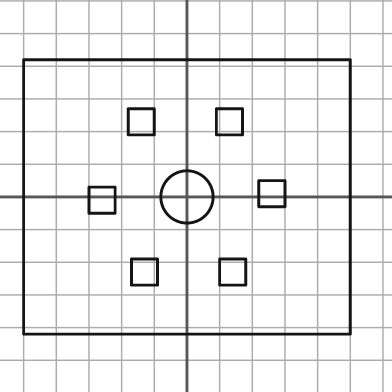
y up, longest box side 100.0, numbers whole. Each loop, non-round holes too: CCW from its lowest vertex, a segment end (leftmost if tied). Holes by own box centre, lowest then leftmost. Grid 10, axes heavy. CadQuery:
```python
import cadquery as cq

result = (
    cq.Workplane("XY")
    .moveTo(-50.0, -42.0)
    .lineTo(50.0, -42.0)
    .lineTo(50.0, 42.0)
    .lineTo(-50.0, 42.0)
    .close()
    .moveTo(-17.0, -27.0)
    .lineTo(-9.0, -27.0)
    .lineTo(-9.0, -19.0)
    .lineTo(-17.0, -19.0)
    .close()
    .moveTo(10.0, -27.0)
    .lineTo(18.0, -27.0)
    .lineTo(18.0, -19.0)
    .lineTo(10.0, -19.0)
    .close()
    .moveTo(-30.0, -5.0)
    .lineTo(-22.0, -5.0)
    .lineTo(-22.0, 3.0)
    .lineTo(-30.0, 3.0)
    .close()
    .moveTo(0.0, 0.0)
    .circle(8.0)
    .moveTo(22.0, -3.0)
    .lineTo(30.0, -3.0)
    .lineTo(30.0, 5.0)
    .lineTo(22.0, 5.0)
    .close()
    .moveTo(-18.0, 19.0)
    .lineTo(-10.0, 19.0)
    .lineTo(-10.0, 27.0)
    .lineTo(-18.0, 27.0)
    .close()
    .moveTo(9.0, 19.0)
    .lineTo(17.0, 19.0)
    .lineTo(17.0, 27.0)
    .lineTo(9.0, 27.0)
    .close()
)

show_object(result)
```